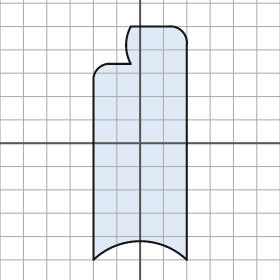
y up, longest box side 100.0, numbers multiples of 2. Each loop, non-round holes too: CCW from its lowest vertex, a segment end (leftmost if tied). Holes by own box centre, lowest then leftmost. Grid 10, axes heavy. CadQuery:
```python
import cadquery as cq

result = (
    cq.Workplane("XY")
    .moveTo(-20.0, -50.0)
    .threePointArc((0.0, -42.0), (20.0, -50.0))
    .lineTo(20.0, 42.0)
    .threePointArc((18.0, 48.0), (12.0, 50.0))
    .lineTo(-4.0, 50.0)
    .threePointArc((-6.0, 42.0), (-4.0, 34.0))
    .lineTo(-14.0, 34.0)
    .threePointArc((-18.0, 32.0), (-20.0, 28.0))
    .close()
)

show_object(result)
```